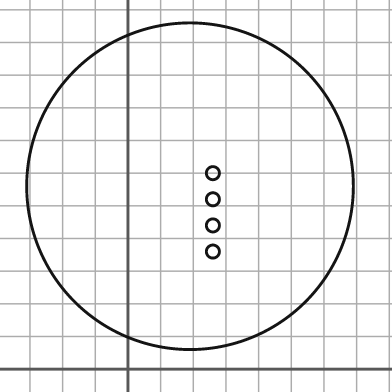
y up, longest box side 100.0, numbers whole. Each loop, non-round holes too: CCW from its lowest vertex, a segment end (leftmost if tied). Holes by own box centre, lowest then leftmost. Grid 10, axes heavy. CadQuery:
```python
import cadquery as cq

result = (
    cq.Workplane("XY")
    .moveTo(19.0, 56.0)
    .circle(50.0)
    .moveTo(26.0, 36.0)
    .circle(2.0)
    .moveTo(26.0, 44.0)
    .circle(2.0)
    .moveTo(26.0, 52.0)
    .circle(2.0)
    .moveTo(26.0, 60.0)
    .circle(2.0)
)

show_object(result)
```